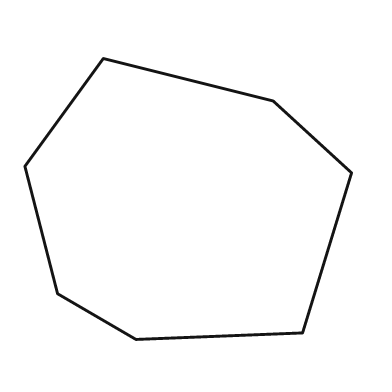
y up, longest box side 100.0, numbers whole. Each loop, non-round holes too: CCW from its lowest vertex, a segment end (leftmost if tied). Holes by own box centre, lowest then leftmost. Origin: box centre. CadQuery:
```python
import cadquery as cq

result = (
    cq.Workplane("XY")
    .moveTo(-16.0, -43.0)
    .lineTo(35.0, -41.0)
    .lineTo(50.0, 8.0)
    .lineTo(26.0, 30.0)
    .lineTo(-26.0, 43.0)
    .lineTo(-50.0, 10.0)
    .lineTo(-40.0, -29.0)
    .close()
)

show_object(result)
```